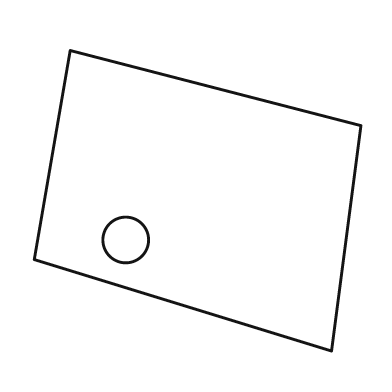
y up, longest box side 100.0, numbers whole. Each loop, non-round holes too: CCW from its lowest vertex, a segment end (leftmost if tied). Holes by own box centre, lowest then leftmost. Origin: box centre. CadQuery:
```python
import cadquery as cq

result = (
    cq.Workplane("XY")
    .moveTo(41.0, -46.0)
    .lineTo(50.0, 23.0)
    .lineTo(-39.0, 46.0)
    .lineTo(-50.0, -18.0)
    .close()
    .moveTo(-22.0, -12.0)
    .circle(7.0)
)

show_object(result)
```